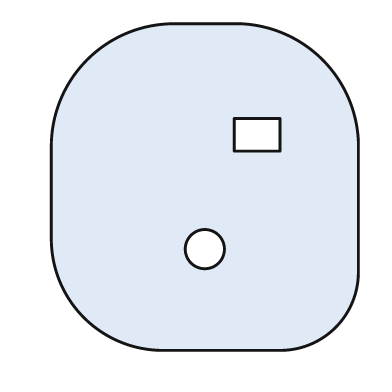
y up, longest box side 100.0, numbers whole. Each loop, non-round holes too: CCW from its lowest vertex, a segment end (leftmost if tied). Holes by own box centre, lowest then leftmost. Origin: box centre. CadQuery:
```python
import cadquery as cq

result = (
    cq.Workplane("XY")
    .moveTo(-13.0, -50.0)
    .lineTo(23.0, -50.0)
    .threePointArc((40.0, -43.0), (47.0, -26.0))
    .lineTo(47.0, 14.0)
    .threePointArc((36.0, 39.0), (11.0, 50.0))
    .lineTo(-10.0, 50.0)
    .threePointArc((-36.0, 39.0), (-47.0, 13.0))
    .lineTo(-47.0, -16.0)
    .threePointArc((-37.0, -40.0), (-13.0, -50.0))
    .close()
    .moveTo(0.0, -19.0)
    .circle(6.0)
    .moveTo(9.0, 11.0)
    .lineTo(23.0, 11.0)
    .lineTo(23.0, 21.0)
    .lineTo(9.0, 21.0)
    .close()
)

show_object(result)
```